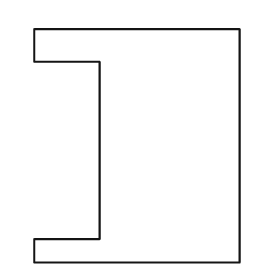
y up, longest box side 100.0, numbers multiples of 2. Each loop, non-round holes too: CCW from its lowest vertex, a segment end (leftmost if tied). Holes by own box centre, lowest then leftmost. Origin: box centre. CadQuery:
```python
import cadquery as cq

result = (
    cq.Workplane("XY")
    .moveTo(-44.0, -50.0)
    .lineTo(44.0, -50.0)
    .lineTo(44.0, 50.0)
    .lineTo(-44.0, 50.0)
    .lineTo(-44.0, 36.0)
    .lineTo(-16.0, 36.0)
    .lineTo(-16.0, -40.0)
    .lineTo(-44.0, -40.0)
    .close()
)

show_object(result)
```